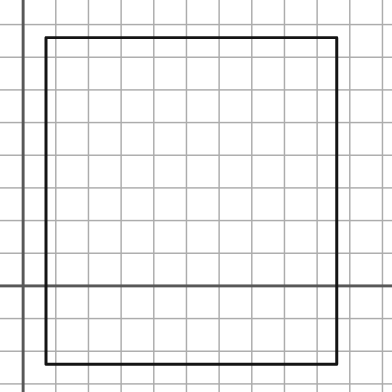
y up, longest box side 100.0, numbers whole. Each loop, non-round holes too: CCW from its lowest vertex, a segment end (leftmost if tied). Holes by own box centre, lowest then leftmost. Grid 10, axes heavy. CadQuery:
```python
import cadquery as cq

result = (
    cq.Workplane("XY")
    .moveTo(7.0, -24.0)
    .lineTo(96.0, -24.0)
    .lineTo(96.0, 76.0)
    .lineTo(7.0, 76.0)
    .close()
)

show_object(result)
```